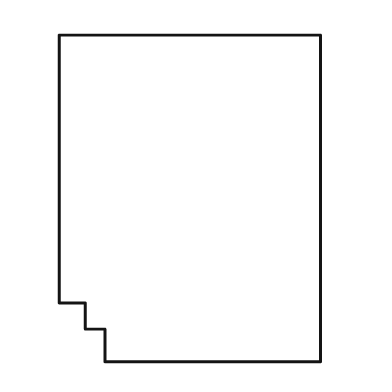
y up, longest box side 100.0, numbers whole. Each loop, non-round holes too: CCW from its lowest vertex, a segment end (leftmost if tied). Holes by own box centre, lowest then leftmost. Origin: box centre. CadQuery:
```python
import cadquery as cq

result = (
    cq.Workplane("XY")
    .moveTo(-26.0, -50.0)
    .lineTo(40.0, -50.0)
    .lineTo(40.0, 50.0)
    .lineTo(-40.0, 50.0)
    .lineTo(-40.0, -32.0)
    .lineTo(-32.0, -32.0)
    .lineTo(-32.0, -40.0)
    .lineTo(-26.0, -40.0)
    .close()
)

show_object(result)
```